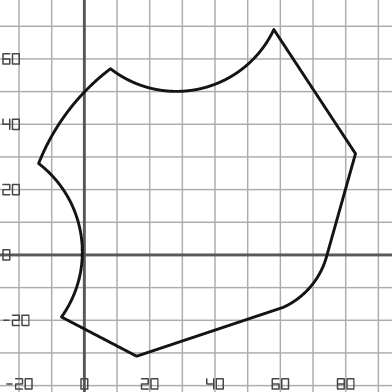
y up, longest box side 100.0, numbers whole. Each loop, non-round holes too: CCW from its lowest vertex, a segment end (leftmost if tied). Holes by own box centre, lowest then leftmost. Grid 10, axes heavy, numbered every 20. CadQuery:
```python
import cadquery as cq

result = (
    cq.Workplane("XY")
    .moveTo(16.0, -31.0)
    .lineTo(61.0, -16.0)
    .threePointArc((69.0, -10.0), (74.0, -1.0))
    .lineTo(83.0, 31.0)
    .lineTo(58.0, 69.0)
    .threePointArc((36.0, 51.0), (8.0, 57.0))
    .threePointArc((-5.0, 44.0), (-14.0, 28.0))
    .threePointArc((-1.0, 6.0), (-7.0, -19.0))
    .close()
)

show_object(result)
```